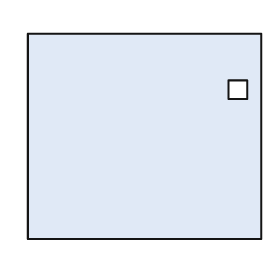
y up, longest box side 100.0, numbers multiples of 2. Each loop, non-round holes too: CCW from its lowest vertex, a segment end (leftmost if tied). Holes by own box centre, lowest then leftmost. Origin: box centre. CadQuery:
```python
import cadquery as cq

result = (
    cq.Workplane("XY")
    .moveTo(-50.0, -44.0)
    .lineTo(50.0, -44.0)
    .lineTo(50.0, 44.0)
    .lineTo(-50.0, 44.0)
    .close()
    .moveTo(36.0, 16.0)
    .lineTo(44.0, 16.0)
    .lineTo(44.0, 24.0)
    .lineTo(36.0, 24.0)
    .close()
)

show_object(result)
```